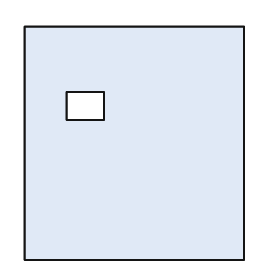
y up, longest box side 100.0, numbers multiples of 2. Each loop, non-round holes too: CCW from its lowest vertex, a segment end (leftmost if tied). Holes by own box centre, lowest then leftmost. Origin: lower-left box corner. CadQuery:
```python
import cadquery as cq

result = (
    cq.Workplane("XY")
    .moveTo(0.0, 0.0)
    .lineTo(94.0, 0.0)
    .lineTo(94.0, 100.0)
    .lineTo(0.0, 100.0)
    .close()
    .moveTo(18.0, 60.0)
    .lineTo(34.0, 60.0)
    .lineTo(34.0, 72.0)
    .lineTo(18.0, 72.0)
    .close()
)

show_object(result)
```